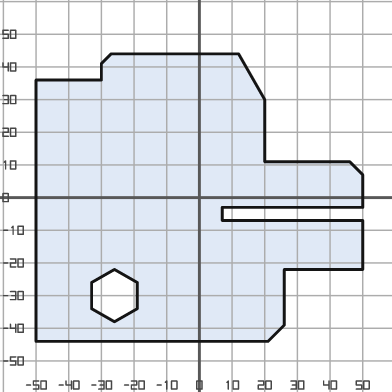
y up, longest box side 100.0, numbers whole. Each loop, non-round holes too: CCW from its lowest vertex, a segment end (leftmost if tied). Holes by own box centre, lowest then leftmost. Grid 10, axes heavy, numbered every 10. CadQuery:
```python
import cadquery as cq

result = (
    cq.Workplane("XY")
    .moveTo(-50.0, -44.0)
    .lineTo(21.0, -44.0)
    .lineTo(26.0, -39.0)
    .lineTo(26.0, -22.0)
    .lineTo(50.0, -22.0)
    .lineTo(50.0, -7.0)
    .lineTo(7.0, -7.0)
    .lineTo(7.0, -3.0)
    .lineTo(50.0, -3.0)
    .lineTo(50.0, 7.0)
    .lineTo(46.0, 11.0)
    .lineTo(20.0, 11.0)
    .lineTo(20.0, 30.0)
    .lineTo(12.0, 44.0)
    .lineTo(-27.0, 44.0)
    .lineTo(-30.0, 41.0)
    .lineTo(-30.0, 36.0)
    .lineTo(-50.0, 36.0)
    .close()
    .moveTo(-26.0, -38.0)
    .lineTo(-19.0, -34.0)
    .lineTo(-19.0, -26.0)
    .lineTo(-26.0, -22.0)
    .lineTo(-33.0, -26.0)
    .lineTo(-33.0, -34.0)
    .close()
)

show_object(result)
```